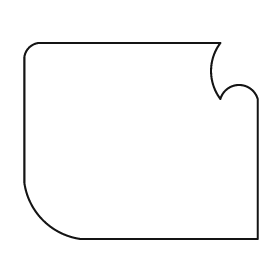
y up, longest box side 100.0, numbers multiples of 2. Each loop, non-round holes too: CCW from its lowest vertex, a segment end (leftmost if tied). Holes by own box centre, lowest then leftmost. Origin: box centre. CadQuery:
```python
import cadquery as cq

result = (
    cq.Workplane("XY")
    .moveTo(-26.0, -42.0)
    .lineTo(50.0, -42.0)
    .lineTo(50.0, 18.0)
    .threePointArc((42.0, 24.0), (34.0, 18.0))
    .threePointArc((30.0, 30.0), (34.0, 42.0))
    .lineTo(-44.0, 42.0)
    .threePointArc((-48.0, 40.0), (-50.0, 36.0))
    .lineTo(-50.0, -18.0)
    .threePointArc((-42.0, -34.0), (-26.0, -42.0))
    .close()
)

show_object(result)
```